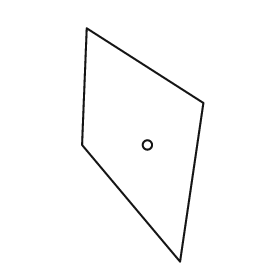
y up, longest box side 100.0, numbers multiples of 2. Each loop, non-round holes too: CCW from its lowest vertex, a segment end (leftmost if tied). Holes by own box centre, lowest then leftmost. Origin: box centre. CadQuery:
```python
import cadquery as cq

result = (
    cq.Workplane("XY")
    .moveTo(16.0, -50.0)
    .lineTo(26.0, 18.0)
    .lineTo(-24.0, 50.0)
    .lineTo(-26.0, 0.0)
    .close()
    .moveTo(2.0, 0.0)
    .circle(2.0)
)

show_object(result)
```